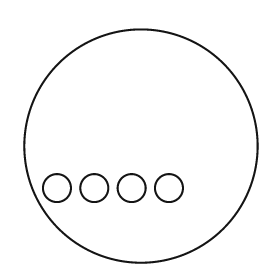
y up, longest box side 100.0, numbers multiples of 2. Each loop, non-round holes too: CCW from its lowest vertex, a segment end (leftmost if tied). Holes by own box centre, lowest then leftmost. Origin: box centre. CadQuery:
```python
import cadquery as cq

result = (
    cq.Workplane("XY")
    .moveTo(0.0, 0.0)
    .circle(50.0)
    .moveTo(-36.0, -18.0)
    .circle(6.0)
    .moveTo(-20.0, -18.0)
    .circle(6.0)
    .moveTo(-4.0, -18.0)
    .circle(6.0)
    .moveTo(12.0, -18.0)
    .circle(6.0)
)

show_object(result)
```